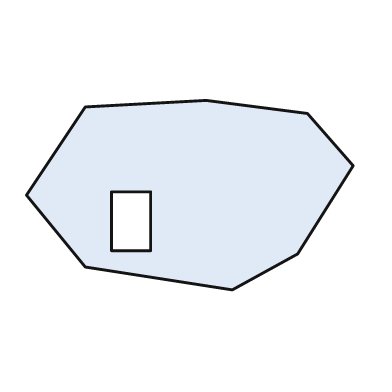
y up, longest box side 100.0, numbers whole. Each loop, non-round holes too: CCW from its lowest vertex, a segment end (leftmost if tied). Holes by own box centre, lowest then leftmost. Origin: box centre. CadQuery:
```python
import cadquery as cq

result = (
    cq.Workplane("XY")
    .moveTo(13.0, -29.0)
    .lineTo(33.0, -18.0)
    .lineTo(50.0, 9.0)
    .lineTo(36.0, 25.0)
    .lineTo(5.0, 29.0)
    .lineTo(-32.0, 27.0)
    .lineTo(-50.0, 0.0)
    .lineTo(-32.0, -22.0)
    .close()
    .moveTo(-24.0, -17.0)
    .lineTo(-12.0, -17.0)
    .lineTo(-12.0, 1.0)
    .lineTo(-24.0, 1.0)
    .close()
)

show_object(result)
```